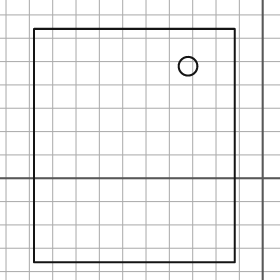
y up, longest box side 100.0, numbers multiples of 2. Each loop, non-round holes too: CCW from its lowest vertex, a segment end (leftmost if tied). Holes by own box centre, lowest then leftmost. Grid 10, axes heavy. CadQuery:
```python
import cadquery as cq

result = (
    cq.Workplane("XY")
    .moveTo(-98.0, -36.0)
    .lineTo(-12.0, -36.0)
    .lineTo(-12.0, 64.0)
    .lineTo(-98.0, 64.0)
    .close()
    .moveTo(-32.0, 48.0)
    .circle(4.0)
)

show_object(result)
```